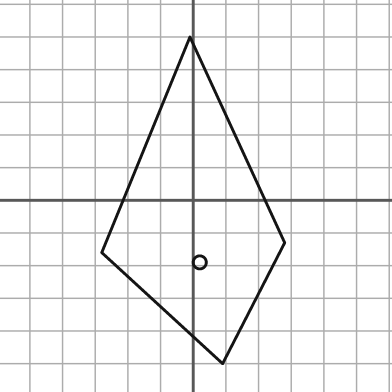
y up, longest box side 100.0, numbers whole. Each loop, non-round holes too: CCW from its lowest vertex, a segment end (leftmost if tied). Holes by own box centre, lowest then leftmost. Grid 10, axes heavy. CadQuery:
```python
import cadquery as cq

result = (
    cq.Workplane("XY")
    .moveTo(9.0, -50.0)
    .lineTo(28.0, -13.0)
    .lineTo(-1.0, 50.0)
    .lineTo(-28.0, -16.0)
    .close()
    .moveTo(2.0, -19.0)
    .circle(2.0)
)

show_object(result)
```